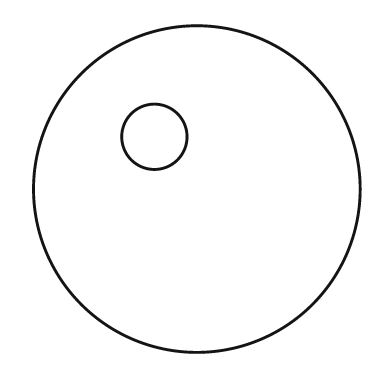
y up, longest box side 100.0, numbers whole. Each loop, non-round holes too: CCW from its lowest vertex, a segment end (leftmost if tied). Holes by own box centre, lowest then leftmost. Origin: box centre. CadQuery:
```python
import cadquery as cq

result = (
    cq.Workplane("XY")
    .moveTo(0.0, 0.0)
    .circle(50.0)
    .moveTo(-13.0, 16.0)
    .circle(10.0)
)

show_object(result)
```